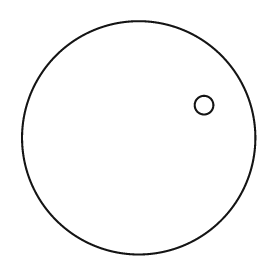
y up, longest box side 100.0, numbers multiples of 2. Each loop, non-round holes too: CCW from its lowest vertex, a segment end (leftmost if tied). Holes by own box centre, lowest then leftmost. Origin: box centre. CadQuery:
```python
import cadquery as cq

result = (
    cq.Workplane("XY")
    .moveTo(0.0, 0.0)
    .circle(50.0)
    .moveTo(28.0, 14.0)
    .circle(4.0)
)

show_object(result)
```